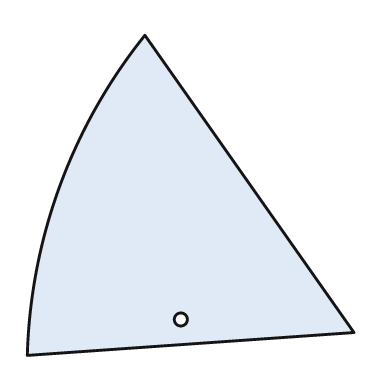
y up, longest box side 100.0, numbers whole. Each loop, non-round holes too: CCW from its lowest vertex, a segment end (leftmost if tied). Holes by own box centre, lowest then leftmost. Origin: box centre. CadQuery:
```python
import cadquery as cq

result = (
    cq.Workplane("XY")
    .moveTo(-50.0, -49.0)
    .lineTo(50.0, -42.0)
    .lineTo(-14.0, 49.0)
    .threePointArc((-40.0, 3.0), (-50.0, -49.0))
    .close()
    .moveTo(-3.0, -38.0)
    .circle(2.0)
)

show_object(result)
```